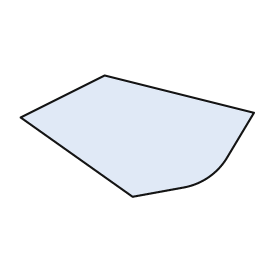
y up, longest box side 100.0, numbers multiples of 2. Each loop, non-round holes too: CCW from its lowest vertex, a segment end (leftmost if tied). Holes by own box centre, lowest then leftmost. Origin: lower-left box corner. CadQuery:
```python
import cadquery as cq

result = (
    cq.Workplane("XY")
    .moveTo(48.0, 0.0)
    .lineTo(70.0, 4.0)
    .threePointArc((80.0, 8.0), (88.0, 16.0))
    .lineTo(100.0, 36.0)
    .lineTo(36.0, 52.0)
    .lineTo(0.0, 34.0)
    .close()
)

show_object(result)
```